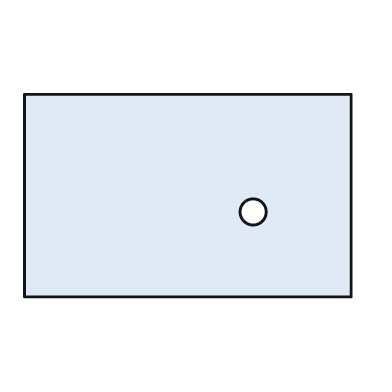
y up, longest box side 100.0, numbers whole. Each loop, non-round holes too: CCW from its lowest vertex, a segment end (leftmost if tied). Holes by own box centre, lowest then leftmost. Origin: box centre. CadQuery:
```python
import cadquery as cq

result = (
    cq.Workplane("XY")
    .moveTo(-50.0, -31.0)
    .lineTo(50.0, -31.0)
    .lineTo(50.0, 31.0)
    .lineTo(-50.0, 31.0)
    .close()
    .moveTo(20.0, -5.0)
    .circle(4.0)
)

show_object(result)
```